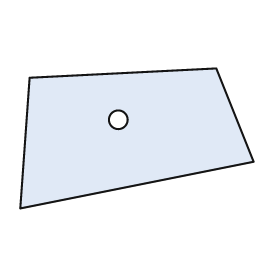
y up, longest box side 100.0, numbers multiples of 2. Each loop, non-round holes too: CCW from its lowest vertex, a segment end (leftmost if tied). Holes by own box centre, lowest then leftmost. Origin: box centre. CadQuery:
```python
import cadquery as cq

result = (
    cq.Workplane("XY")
    .moveTo(-50.0, -30.0)
    .lineTo(50.0, -10.0)
    .lineTo(34.0, 30.0)
    .lineTo(-46.0, 26.0)
    .close()
    .moveTo(-8.0, 8.0)
    .circle(4.0)
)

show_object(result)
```